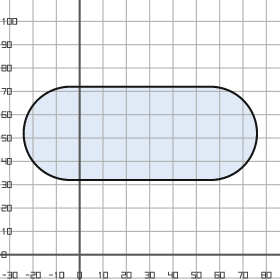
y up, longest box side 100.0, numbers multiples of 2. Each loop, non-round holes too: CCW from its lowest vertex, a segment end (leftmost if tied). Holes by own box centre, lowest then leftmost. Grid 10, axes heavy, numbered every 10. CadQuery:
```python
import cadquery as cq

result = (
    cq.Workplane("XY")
    .moveTo(-4.0, 32.0)
    .lineTo(56.0, 32.0)
    .threePointArc((76.0, 52.0), (56.0, 72.0))
    .lineTo(-4.0, 72.0)
    .threePointArc((-24.0, 52.0), (-4.0, 32.0))
    .close()
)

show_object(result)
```